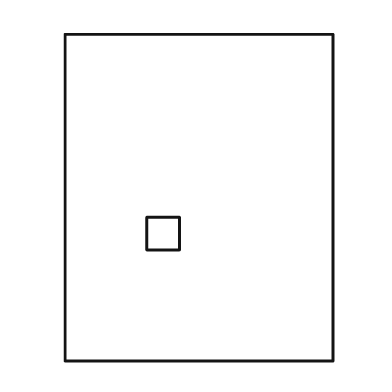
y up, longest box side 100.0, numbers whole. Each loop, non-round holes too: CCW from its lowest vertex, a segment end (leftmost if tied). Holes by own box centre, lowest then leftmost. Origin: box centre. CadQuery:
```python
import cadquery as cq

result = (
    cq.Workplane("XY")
    .moveTo(-41.0, -50.0)
    .lineTo(41.0, -50.0)
    .lineTo(41.0, 50.0)
    .lineTo(-41.0, 50.0)
    .close()
    .moveTo(-16.0, -16.0)
    .lineTo(-6.0, -16.0)
    .lineTo(-6.0, -6.0)
    .lineTo(-16.0, -6.0)
    .close()
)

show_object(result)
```